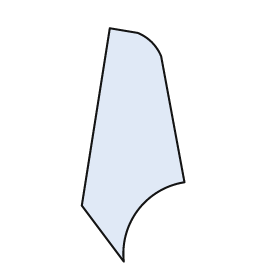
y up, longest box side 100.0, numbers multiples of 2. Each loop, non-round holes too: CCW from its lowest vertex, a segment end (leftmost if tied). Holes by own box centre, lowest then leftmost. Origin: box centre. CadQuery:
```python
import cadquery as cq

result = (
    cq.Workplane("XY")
    .moveTo(-4.0, -50.0)
    .threePointArc((2.0, -28.0), (22.0, -16.0))
    .lineTo(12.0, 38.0)
    .threePointArc((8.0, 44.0), (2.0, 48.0))
    .lineTo(-10.0, 50.0)
    .lineTo(-22.0, -26.0)
    .close()
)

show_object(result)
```